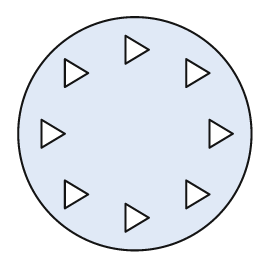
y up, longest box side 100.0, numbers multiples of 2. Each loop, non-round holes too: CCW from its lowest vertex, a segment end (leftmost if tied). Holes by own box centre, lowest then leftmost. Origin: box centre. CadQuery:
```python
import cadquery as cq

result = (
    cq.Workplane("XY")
    .moveTo(0.0, 0.0)
    .circle(50.0)
    .moveTo(-4.0, -42.0)
    .lineTo(6.0, -36.0)
    .lineTo(-4.0, -30.0)
    .close()
    .moveTo(-30.0, -32.0)
    .lineTo(-20.0, -26.0)
    .lineTo(-30.0, -20.0)
    .close()
    .moveTo(22.0, -32.0)
    .lineTo(32.0, -26.0)
    .lineTo(22.0, -20.0)
    .close()
    .moveTo(-40.0, -6.0)
    .lineTo(-30.0, 0.0)
    .lineTo(-40.0, 6.0)
    .close()
    .moveTo(32.0, -6.0)
    .lineTo(42.0, 0.0)
    .lineTo(32.0, 6.0)
    .close()
    .moveTo(-30.0, 20.0)
    .lineTo(-20.0, 26.0)
    .lineTo(-30.0, 32.0)
    .close()
    .moveTo(22.0, 20.0)
    .lineTo(32.0, 26.0)
    .lineTo(22.0, 32.0)
    .close()
    .moveTo(-4.0, 30.0)
    .lineTo(6.0, 36.0)
    .lineTo(-4.0, 42.0)
    .close()
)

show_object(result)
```